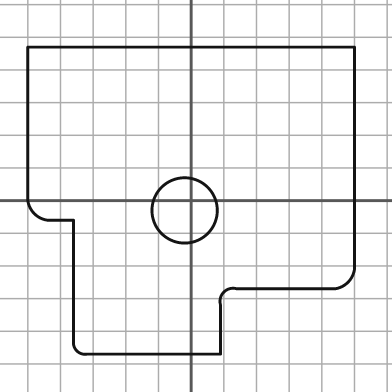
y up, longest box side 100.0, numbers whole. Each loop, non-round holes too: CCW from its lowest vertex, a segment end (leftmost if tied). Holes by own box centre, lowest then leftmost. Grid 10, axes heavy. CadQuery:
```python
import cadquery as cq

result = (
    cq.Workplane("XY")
    .moveTo(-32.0, -47.0)
    .lineTo(9.0, -47.0)
    .lineTo(9.0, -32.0)
    .threePointArc((10.0, -28.0), (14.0, -27.0))
    .lineTo(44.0, -27.0)
    .threePointArc((48.0, -25.0), (50.0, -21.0))
    .lineTo(50.0, 47.0)
    .lineTo(-50.0, 47.0)
    .lineTo(-50.0, 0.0)
    .threePointArc((-48.0, -4.0), (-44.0, -6.0))
    .lineTo(-36.0, -6.0)
    .lineTo(-36.0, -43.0)
    .threePointArc((-35.0, -46.0), (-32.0, -47.0))
    .close()
    .moveTo(-2.0, -3.0)
    .circle(10.0)
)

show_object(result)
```